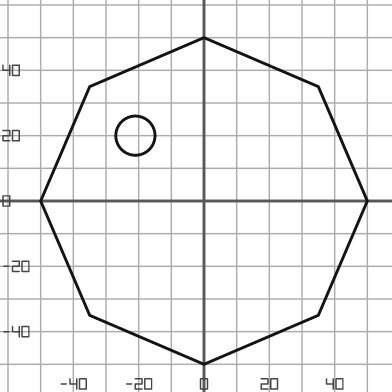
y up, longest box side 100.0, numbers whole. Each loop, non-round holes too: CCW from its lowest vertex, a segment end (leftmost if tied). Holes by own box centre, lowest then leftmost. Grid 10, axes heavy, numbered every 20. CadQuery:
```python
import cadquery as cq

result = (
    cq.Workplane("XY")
    .moveTo(0.0, -50.0)
    .lineTo(35.0, -35.0)
    .lineTo(50.0, 0.0)
    .lineTo(35.0, 35.0)
    .lineTo(0.0, 50.0)
    .lineTo(-35.0, 35.0)
    .lineTo(-50.0, 0.0)
    .lineTo(-35.0, -35.0)
    .close()
    .moveTo(-21.0, 20.0)
    .circle(6.0)
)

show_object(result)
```